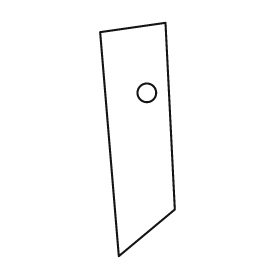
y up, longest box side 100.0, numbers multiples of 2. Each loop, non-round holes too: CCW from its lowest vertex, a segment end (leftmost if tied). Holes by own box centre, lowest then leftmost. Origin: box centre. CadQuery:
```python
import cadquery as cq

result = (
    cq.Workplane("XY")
    .moveTo(-8.0, -50.0)
    .lineTo(16.0, -30.0)
    .lineTo(12.0, 50.0)
    .lineTo(-16.0, 46.0)
    .close()
    .moveTo(4.0, 20.0)
    .circle(4.0)
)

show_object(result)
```